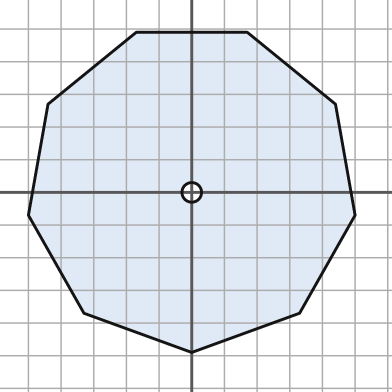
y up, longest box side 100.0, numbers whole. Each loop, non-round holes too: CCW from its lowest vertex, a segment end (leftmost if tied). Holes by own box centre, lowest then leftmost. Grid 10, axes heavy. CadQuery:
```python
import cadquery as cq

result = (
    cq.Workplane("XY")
    .moveTo(0.0, -49.0)
    .lineTo(33.0, -37.0)
    .lineTo(50.0, -7.0)
    .lineTo(44.0, 27.0)
    .lineTo(17.0, 49.0)
    .lineTo(-17.0, 49.0)
    .lineTo(-44.0, 27.0)
    .lineTo(-50.0, -7.0)
    .lineTo(-33.0, -37.0)
    .close()
    .moveTo(0.0, 0.0)
    .circle(3.0)
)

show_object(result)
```